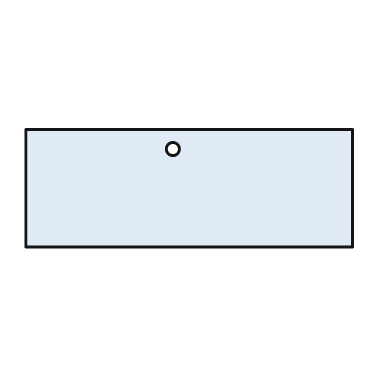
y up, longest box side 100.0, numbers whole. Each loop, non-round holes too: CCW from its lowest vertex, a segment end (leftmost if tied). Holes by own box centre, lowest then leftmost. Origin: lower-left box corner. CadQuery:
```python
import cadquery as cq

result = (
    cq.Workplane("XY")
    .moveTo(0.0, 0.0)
    .lineTo(100.0, 0.0)
    .lineTo(100.0, 36.0)
    .lineTo(0.0, 36.0)
    .close()
    .moveTo(45.0, 30.0)
    .circle(2.0)
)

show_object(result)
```